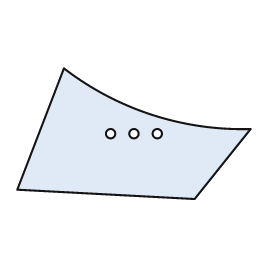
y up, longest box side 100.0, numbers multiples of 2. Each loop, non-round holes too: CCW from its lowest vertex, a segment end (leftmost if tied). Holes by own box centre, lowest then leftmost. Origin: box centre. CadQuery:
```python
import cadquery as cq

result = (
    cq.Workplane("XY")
    .moveTo(26.0, -28.0)
    .lineTo(50.0, 2.0)
    .threePointArc((8.0, 8.0), (-30.0, 28.0))
    .lineTo(-50.0, -24.0)
    .close()
    .moveTo(-10.0, 0.0)
    .circle(2.0)
    .moveTo(0.0, 0.0)
    .circle(2.0)
    .moveTo(10.0, 0.0)
    .circle(2.0)
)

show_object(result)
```